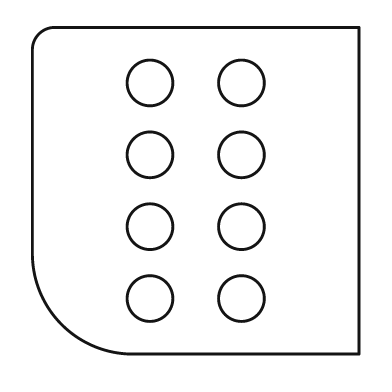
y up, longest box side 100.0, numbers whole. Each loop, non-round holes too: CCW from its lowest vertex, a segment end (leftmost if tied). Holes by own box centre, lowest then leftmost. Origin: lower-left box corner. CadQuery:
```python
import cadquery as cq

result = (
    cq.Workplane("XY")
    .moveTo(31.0, 0.0)
    .lineTo(100.0, 0.0)
    .lineTo(100.0, 100.0)
    .lineTo(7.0, 100.0)
    .threePointArc((2.0, 98.0), (0.0, 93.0))
    .lineTo(0.0, 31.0)
    .threePointArc((9.0, 9.0), (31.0, 0.0))
    .close()
    .moveTo(36.0, 17.0)
    .circle(7.0)
    .moveTo(64.0, 17.0)
    .circle(7.0)
    .moveTo(36.0, 39.0)
    .circle(7.0)
    .moveTo(64.0, 39.0)
    .circle(7.0)
    .moveTo(36.0, 61.0)
    .circle(7.0)
    .moveTo(64.0, 61.0)
    .circle(7.0)
    .moveTo(36.0, 83.0)
    .circle(7.0)
    .moveTo(64.0, 83.0)
    .circle(7.0)
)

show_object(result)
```